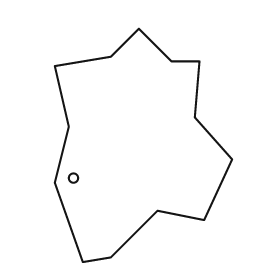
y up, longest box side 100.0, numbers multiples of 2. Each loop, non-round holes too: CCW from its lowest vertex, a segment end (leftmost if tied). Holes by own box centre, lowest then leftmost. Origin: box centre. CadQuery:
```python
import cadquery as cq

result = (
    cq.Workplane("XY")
    .moveTo(-26.0, -50.0)
    .lineTo(-14.0, -48.0)
    .lineTo(6.0, -28.0)
    .lineTo(26.0, -32.0)
    .lineTo(38.0, -6.0)
    .lineTo(22.0, 12.0)
    .lineTo(24.0, 36.0)
    .lineTo(12.0, 36.0)
    .lineTo(-2.0, 50.0)
    .lineTo(-14.0, 38.0)
    .lineTo(-38.0, 34.0)
    .lineTo(-32.0, 8.0)
    .lineTo(-38.0, -16.0)
    .close()
    .moveTo(-30.0, -14.0)
    .circle(2.0)
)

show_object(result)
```